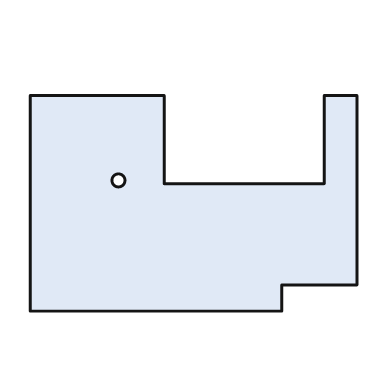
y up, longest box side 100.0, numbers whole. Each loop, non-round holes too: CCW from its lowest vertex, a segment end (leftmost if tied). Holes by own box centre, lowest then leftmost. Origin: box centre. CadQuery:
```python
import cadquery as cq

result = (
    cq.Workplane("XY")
    .moveTo(-50.0, -33.0)
    .lineTo(27.0, -33.0)
    .lineTo(27.0, -25.0)
    .lineTo(50.0, -25.0)
    .lineTo(50.0, 33.0)
    .lineTo(40.0, 33.0)
    .lineTo(40.0, 6.0)
    .lineTo(-9.0, 6.0)
    .lineTo(-9.0, 33.0)
    .lineTo(-50.0, 33.0)
    .close()
    .moveTo(-23.0, 7.0)
    .circle(2.0)
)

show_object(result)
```